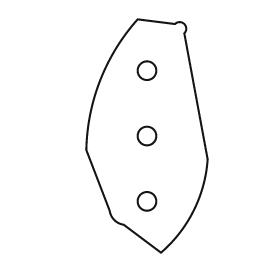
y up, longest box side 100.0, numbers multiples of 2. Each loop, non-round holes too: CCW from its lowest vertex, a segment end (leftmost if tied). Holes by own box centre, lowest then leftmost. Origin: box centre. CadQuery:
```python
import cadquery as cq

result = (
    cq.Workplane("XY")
    .moveTo(6.0, -50.0)
    .threePointArc((20.0, -32.0), (26.0, -10.0))
    .lineTo(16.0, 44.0)
    .threePointArc((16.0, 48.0), (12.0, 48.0))
    .lineTo(-4.0, 50.0)
    .threePointArc((-20.0, 24.0), (-26.0, -6.0))
    .lineTo(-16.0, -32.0)
    .threePointArc((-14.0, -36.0), (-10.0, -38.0))
    .close()
    .moveTo(0.0, -28.0)
    .circle(4.0)
    .moveTo(0.0, 0.0)
    .circle(4.0)
    .moveTo(0.0, 28.0)
    .circle(4.0)
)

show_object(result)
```